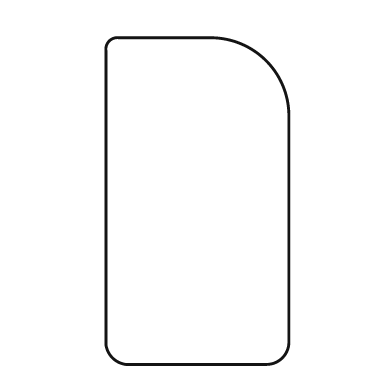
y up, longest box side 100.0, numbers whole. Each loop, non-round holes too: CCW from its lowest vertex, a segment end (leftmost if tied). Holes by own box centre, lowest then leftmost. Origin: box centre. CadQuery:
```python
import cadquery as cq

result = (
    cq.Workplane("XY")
    .moveTo(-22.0, -50.0)
    .lineTo(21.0, -50.0)
    .threePointArc((26.0, -48.0), (28.0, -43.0))
    .lineTo(28.0, 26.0)
    .threePointArc((21.0, 43.0), (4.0, 50.0))
    .lineTo(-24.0, 50.0)
    .threePointArc((-27.0, 49.0), (-28.0, 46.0))
    .lineTo(-28.0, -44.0)
    .threePointArc((-26.0, -48.0), (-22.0, -50.0))
    .close()
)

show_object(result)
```